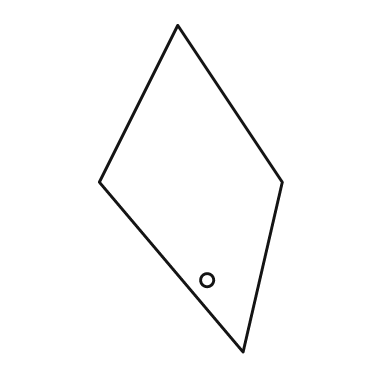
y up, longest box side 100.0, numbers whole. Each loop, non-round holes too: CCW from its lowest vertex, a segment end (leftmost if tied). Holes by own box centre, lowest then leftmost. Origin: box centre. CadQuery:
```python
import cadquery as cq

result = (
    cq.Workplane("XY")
    .moveTo(16.0, -50.0)
    .lineTo(28.0, 2.0)
    .lineTo(-4.0, 50.0)
    .lineTo(-28.0, 2.0)
    .close()
    .moveTo(5.0, -28.0)
    .circle(2.0)
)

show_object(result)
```